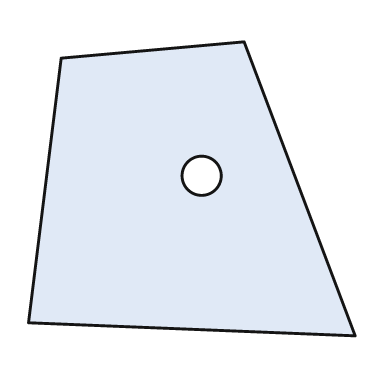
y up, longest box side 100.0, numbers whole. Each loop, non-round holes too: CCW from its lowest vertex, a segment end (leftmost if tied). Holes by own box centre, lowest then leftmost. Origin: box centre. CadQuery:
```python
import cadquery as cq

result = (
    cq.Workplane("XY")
    .moveTo(50.0, -45.0)
    .lineTo(16.0, 45.0)
    .lineTo(-40.0, 40.0)
    .lineTo(-50.0, -41.0)
    .close()
    .moveTo(3.0, 4.0)
    .circle(6.0)
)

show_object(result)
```